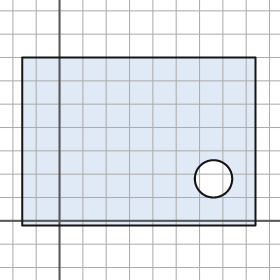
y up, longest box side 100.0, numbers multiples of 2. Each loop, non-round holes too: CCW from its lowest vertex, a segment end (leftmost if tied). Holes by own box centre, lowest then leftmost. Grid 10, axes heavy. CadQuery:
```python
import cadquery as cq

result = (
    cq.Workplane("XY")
    .moveTo(-16.0, -2.0)
    .lineTo(84.0, -2.0)
    .lineTo(84.0, 70.0)
    .lineTo(-16.0, 70.0)
    .close()
    .moveTo(66.0, 18.0)
    .circle(8.0)
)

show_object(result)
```